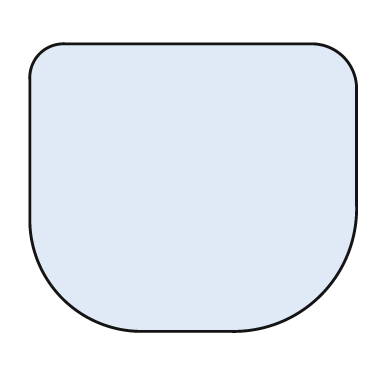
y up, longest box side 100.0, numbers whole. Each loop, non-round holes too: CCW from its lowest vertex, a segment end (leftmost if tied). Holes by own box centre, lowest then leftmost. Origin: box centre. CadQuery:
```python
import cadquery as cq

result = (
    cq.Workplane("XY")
    .moveTo(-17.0, -44.0)
    .lineTo(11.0, -44.0)
    .threePointArc((39.0, -33.0), (50.0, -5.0))
    .lineTo(50.0, 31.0)
    .threePointArc((46.0, 40.0), (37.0, 44.0))
    .lineTo(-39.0, 44.0)
    .threePointArc((-47.0, 41.0), (-50.0, 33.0))
    .lineTo(-50.0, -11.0)
    .threePointArc((-40.0, -34.0), (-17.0, -44.0))
    .close()
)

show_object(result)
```